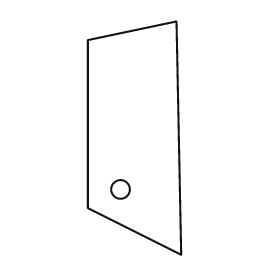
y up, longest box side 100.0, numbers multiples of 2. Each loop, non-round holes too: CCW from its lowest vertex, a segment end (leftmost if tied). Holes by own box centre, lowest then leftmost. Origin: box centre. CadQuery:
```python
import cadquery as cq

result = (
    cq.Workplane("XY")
    .moveTo(20.0, -50.0)
    .lineTo(18.0, 50.0)
    .lineTo(-20.0, 42.0)
    .lineTo(-20.0, -30.0)
    .close()
    .moveTo(-6.0, -22.0)
    .circle(4.0)
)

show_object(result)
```